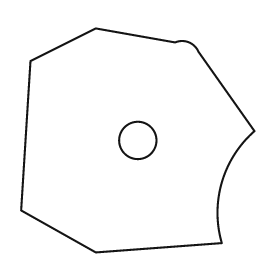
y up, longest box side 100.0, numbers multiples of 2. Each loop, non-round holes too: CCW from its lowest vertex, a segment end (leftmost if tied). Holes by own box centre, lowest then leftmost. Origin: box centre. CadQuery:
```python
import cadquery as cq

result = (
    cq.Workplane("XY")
    .moveTo(-18.0, -48.0)
    .lineTo(36.0, -44.0)
    .threePointArc((36.0, -18.0), (50.0, 4.0))
    .lineTo(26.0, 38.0)
    .threePointArc((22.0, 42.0), (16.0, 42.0))
    .lineTo(-18.0, 48.0)
    .lineTo(-46.0, 34.0)
    .lineTo(-50.0, -30.0)
    .close()
    .moveTo(0.0, 0.0)
    .circle(8.0)
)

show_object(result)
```